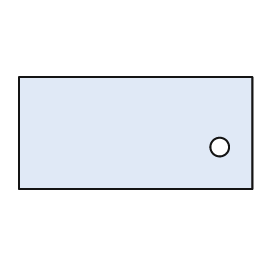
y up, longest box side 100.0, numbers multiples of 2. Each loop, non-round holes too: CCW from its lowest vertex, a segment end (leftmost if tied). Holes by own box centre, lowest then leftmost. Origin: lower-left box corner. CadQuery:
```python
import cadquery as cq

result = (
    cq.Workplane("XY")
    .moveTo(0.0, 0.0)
    .lineTo(100.0, 0.0)
    .lineTo(100.0, 48.0)
    .lineTo(0.0, 48.0)
    .close()
    .moveTo(86.0, 18.0)
    .circle(4.0)
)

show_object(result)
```